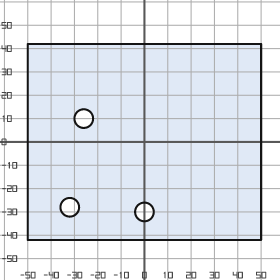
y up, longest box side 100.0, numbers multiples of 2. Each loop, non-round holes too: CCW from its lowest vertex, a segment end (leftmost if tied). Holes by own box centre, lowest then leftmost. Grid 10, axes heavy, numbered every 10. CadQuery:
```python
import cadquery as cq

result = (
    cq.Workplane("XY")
    .moveTo(-50.0, -42.0)
    .lineTo(50.0, -42.0)
    .lineTo(50.0, 42.0)
    .lineTo(-50.0, 42.0)
    .close()
    .moveTo(0.0, -30.0)
    .circle(4.0)
    .moveTo(-32.0, -28.0)
    .circle(4.0)
    .moveTo(-26.0, 10.0)
    .circle(4.0)
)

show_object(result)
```